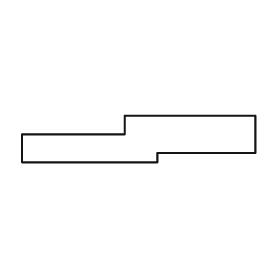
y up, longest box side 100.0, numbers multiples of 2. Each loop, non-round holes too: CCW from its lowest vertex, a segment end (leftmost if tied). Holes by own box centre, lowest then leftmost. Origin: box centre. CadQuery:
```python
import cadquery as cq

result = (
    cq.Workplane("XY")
    .moveTo(-50.0, -10.0)
    .lineTo(8.0, -10.0)
    .lineTo(8.0, -6.0)
    .lineTo(50.0, -6.0)
    .lineTo(50.0, 10.0)
    .lineTo(-6.0, 10.0)
    .lineTo(-6.0, 2.0)
    .lineTo(-50.0, 2.0)
    .close()
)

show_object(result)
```